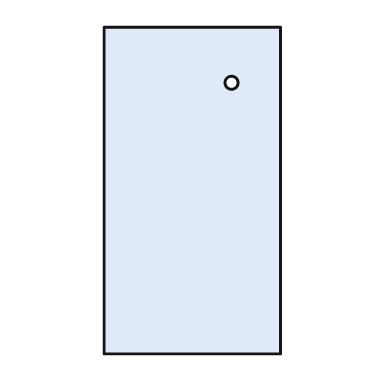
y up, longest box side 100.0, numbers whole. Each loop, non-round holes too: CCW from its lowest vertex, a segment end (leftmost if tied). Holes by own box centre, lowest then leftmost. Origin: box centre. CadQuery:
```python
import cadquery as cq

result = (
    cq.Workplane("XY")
    .moveTo(-27.0, -50.0)
    .lineTo(27.0, -50.0)
    .lineTo(27.0, 50.0)
    .lineTo(-27.0, 50.0)
    .close()
    .moveTo(12.0, 33.0)
    .circle(2.0)
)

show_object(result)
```